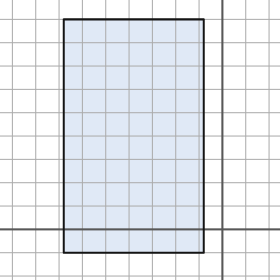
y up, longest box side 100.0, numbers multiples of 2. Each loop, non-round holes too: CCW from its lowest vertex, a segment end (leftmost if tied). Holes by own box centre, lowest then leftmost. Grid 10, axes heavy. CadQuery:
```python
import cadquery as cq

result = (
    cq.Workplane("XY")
    .moveTo(-68.0, -10.0)
    .lineTo(-8.0, -10.0)
    .lineTo(-8.0, 90.0)
    .lineTo(-68.0, 90.0)
    .close()
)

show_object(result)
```